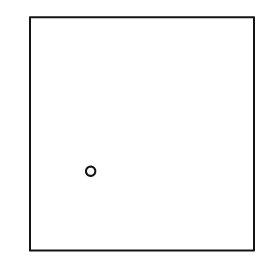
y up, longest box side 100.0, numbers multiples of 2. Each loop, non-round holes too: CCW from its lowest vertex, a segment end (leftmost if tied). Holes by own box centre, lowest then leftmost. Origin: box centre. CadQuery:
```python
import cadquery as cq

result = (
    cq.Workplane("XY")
    .moveTo(-48.0, -50.0)
    .lineTo(48.0, -50.0)
    .lineTo(48.0, 50.0)
    .lineTo(-48.0, 50.0)
    .close()
    .moveTo(-22.0, -16.0)
    .circle(2.0)
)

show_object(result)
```